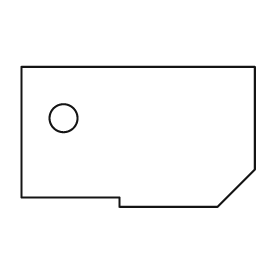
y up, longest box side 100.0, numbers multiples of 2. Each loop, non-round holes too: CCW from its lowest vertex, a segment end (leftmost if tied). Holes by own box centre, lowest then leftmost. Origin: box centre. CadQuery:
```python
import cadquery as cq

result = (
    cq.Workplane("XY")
    .moveTo(-8.0, -30.0)
    .lineTo(34.0, -30.0)
    .lineTo(50.0, -14.0)
    .lineTo(50.0, 30.0)
    .lineTo(-50.0, 30.0)
    .lineTo(-50.0, -26.0)
    .lineTo(-8.0, -26.0)
    .close()
    .moveTo(-32.0, 8.0)
    .circle(6.0)
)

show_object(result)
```